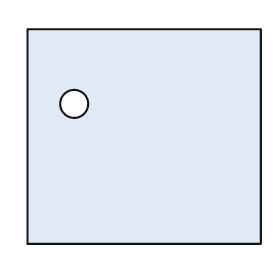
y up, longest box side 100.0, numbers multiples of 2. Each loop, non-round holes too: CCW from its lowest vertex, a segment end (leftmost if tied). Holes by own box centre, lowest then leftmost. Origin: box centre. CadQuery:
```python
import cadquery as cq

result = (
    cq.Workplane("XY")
    .moveTo(-50.0, -46.0)
    .lineTo(50.0, -46.0)
    .lineTo(50.0, 46.0)
    .lineTo(-50.0, 46.0)
    .close()
    .moveTo(-30.0, 14.0)
    .circle(6.0)
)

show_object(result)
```